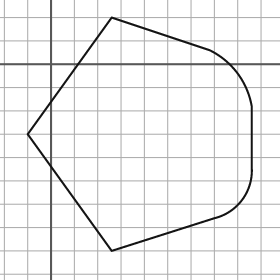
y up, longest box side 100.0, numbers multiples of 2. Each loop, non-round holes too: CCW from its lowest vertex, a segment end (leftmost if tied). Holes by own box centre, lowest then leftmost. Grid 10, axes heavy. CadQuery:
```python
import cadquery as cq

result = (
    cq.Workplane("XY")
    .moveTo(26.0, -80.0)
    .lineTo(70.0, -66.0)
    .threePointArc((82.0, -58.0), (86.0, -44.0))
    .lineTo(86.0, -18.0)
    .threePointArc((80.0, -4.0), (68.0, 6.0))
    .lineTo(26.0, 20.0)
    .lineTo(-10.0, -30.0)
    .close()
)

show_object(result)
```